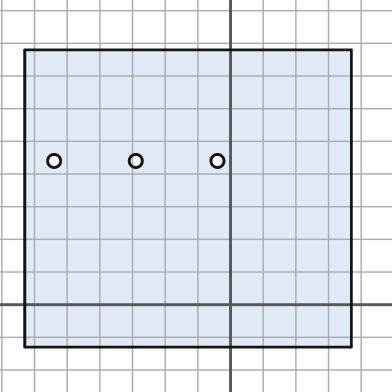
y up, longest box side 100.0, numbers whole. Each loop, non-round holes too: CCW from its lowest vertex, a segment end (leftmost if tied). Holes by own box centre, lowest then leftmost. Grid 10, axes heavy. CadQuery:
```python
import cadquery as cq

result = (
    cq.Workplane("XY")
    .moveTo(-63.0, -13.0)
    .lineTo(37.0, -13.0)
    .lineTo(37.0, 78.0)
    .lineTo(-63.0, 78.0)
    .close()
    .moveTo(-54.0, 44.0)
    .circle(2.0)
    .moveTo(-29.0, 44.0)
    .circle(2.0)
    .moveTo(-4.0, 44.0)
    .circle(2.0)
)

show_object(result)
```